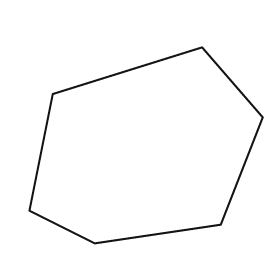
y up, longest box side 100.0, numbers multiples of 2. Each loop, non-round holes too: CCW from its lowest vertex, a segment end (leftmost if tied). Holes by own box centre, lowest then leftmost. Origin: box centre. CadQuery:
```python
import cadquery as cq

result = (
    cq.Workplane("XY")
    .moveTo(-22.0, -42.0)
    .lineTo(32.0, -34.0)
    .lineTo(50.0, 12.0)
    .lineTo(24.0, 42.0)
    .lineTo(-40.0, 22.0)
    .lineTo(-50.0, -28.0)
    .close()
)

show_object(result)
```